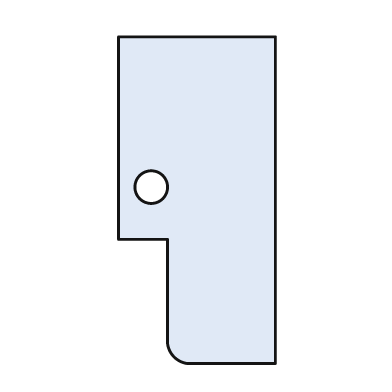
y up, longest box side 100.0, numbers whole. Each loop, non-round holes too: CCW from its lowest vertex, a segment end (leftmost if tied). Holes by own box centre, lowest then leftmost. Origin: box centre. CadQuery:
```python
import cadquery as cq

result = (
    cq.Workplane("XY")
    .moveTo(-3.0, -50.0)
    .lineTo(24.0, -50.0)
    .lineTo(24.0, 50.0)
    .lineTo(-24.0, 50.0)
    .lineTo(-24.0, -12.0)
    .lineTo(-9.0, -12.0)
    .lineTo(-9.0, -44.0)
    .threePointArc((-7.0, -48.0), (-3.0, -50.0))
    .close()
    .moveTo(-14.0, 4.0)
    .circle(5.0)
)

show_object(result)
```